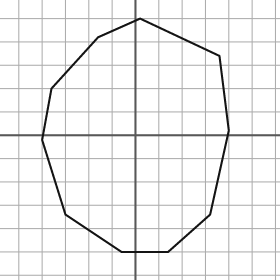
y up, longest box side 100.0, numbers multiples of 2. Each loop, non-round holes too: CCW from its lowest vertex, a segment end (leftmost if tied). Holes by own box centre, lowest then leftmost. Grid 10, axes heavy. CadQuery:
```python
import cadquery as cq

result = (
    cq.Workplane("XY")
    .moveTo(-6.0, -50.0)
    .lineTo(14.0, -50.0)
    .lineTo(32.0, -34.0)
    .lineTo(40.0, 2.0)
    .lineTo(36.0, 34.0)
    .lineTo(2.0, 50.0)
    .lineTo(-16.0, 42.0)
    .lineTo(-36.0, 20.0)
    .lineTo(-40.0, -2.0)
    .lineTo(-30.0, -34.0)
    .close()
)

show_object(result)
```